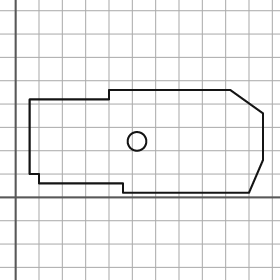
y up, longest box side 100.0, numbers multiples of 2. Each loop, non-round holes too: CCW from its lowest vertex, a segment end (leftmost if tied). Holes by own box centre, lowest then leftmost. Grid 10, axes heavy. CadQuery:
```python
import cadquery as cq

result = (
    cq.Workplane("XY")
    .moveTo(46.0, 2.0)
    .lineTo(100.0, 2.0)
    .lineTo(106.0, 16.0)
    .lineTo(106.0, 36.0)
    .lineTo(92.0, 46.0)
    .lineTo(40.0, 46.0)
    .lineTo(40.0, 42.0)
    .lineTo(6.0, 42.0)
    .lineTo(6.0, 10.0)
    .lineTo(10.0, 10.0)
    .lineTo(10.0, 6.0)
    .lineTo(46.0, 6.0)
    .close()
    .moveTo(52.0, 24.0)
    .circle(4.0)
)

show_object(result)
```